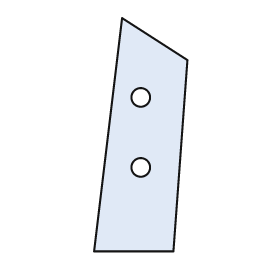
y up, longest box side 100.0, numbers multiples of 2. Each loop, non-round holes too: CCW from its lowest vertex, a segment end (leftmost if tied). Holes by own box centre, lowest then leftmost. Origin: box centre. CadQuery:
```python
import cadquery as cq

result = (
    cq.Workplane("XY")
    .moveTo(-20.0, -50.0)
    .lineTo(14.0, -50.0)
    .lineTo(20.0, 32.0)
    .lineTo(-8.0, 50.0)
    .close()
    .moveTo(0.0, -14.0)
    .circle(4.0)
    .moveTo(0.0, 16.0)
    .circle(4.0)
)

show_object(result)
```